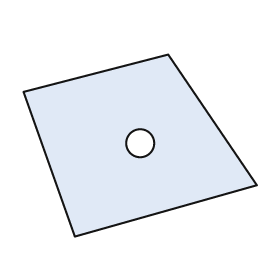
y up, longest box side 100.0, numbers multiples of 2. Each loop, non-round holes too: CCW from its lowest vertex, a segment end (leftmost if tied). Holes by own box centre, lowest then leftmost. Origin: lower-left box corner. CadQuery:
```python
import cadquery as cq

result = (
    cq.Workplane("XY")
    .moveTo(22.0, 0.0)
    .lineTo(100.0, 22.0)
    .lineTo(62.0, 78.0)
    .lineTo(0.0, 62.0)
    .close()
    .moveTo(50.0, 40.0)
    .circle(6.0)
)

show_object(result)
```